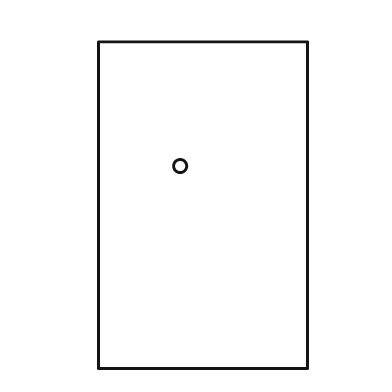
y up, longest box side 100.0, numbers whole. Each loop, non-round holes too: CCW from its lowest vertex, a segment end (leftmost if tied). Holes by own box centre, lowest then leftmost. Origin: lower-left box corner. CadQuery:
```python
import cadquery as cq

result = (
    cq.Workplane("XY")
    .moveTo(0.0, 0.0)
    .lineTo(64.0, 0.0)
    .lineTo(64.0, 100.0)
    .lineTo(0.0, 100.0)
    .close()
    .moveTo(25.0, 62.0)
    .circle(2.0)
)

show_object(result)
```